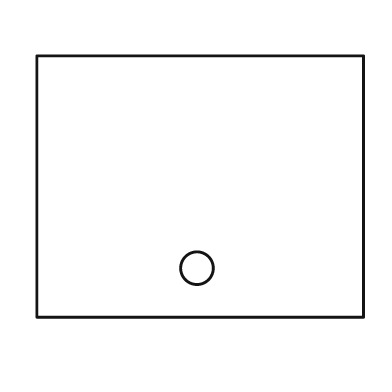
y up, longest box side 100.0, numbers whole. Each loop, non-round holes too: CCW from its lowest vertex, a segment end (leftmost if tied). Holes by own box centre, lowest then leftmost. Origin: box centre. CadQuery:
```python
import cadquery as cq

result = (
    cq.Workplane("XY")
    .moveTo(-50.0, -40.0)
    .lineTo(50.0, -40.0)
    .lineTo(50.0, 40.0)
    .lineTo(-50.0, 40.0)
    .close()
    .moveTo(-1.0, -25.0)
    .circle(5.0)
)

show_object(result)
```